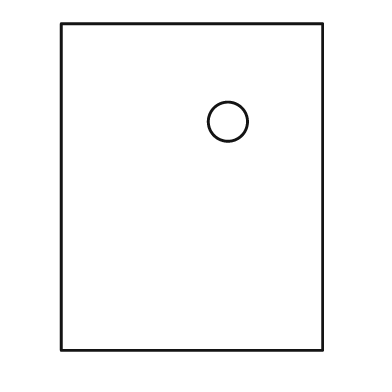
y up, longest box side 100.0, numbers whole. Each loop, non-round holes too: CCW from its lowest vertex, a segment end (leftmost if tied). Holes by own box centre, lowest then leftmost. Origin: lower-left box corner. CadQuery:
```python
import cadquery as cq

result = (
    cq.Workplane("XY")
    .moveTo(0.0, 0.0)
    .lineTo(80.0, 0.0)
    .lineTo(80.0, 100.0)
    .lineTo(0.0, 100.0)
    .close()
    .moveTo(51.0, 70.0)
    .circle(6.0)
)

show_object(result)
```